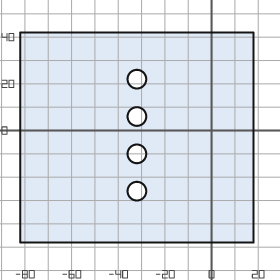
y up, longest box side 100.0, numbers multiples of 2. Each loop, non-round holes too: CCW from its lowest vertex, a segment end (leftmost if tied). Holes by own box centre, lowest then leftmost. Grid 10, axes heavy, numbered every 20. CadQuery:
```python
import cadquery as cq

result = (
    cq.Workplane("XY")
    .moveTo(-82.0, -48.0)
    .lineTo(18.0, -48.0)
    .lineTo(18.0, 42.0)
    .lineTo(-82.0, 42.0)
    .close()
    .moveTo(-32.0, -26.0)
    .circle(4.0)
    .moveTo(-32.0, -10.0)
    .circle(4.0)
    .moveTo(-32.0, 6.0)
    .circle(4.0)
    .moveTo(-32.0, 22.0)
    .circle(4.0)
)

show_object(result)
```